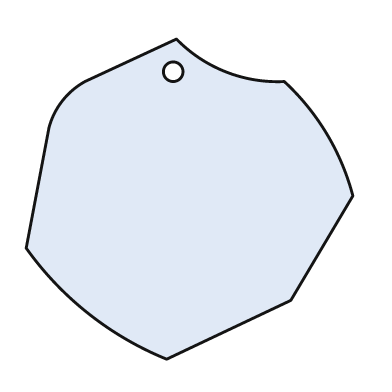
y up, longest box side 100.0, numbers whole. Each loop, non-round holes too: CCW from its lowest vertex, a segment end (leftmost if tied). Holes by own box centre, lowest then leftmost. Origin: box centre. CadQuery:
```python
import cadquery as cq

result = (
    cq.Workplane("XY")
    .moveTo(-7.0, -49.0)
    .lineTo(31.0, -31.0)
    .lineTo(50.0, 1.0)
    .threePointArc((42.0, 20.0), (29.0, 36.0))
    .threePointArc((11.0, 39.0), (-4.0, 49.0))
    .lineTo(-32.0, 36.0)
    .threePointArc((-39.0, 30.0), (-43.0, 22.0))
    .lineTo(-50.0, -15.0)
    .threePointArc((-31.0, -35.0), (-7.0, -49.0))
    .close()
    .moveTo(-5.0, 39.0)
    .circle(3.0)
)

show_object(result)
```